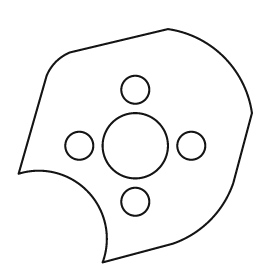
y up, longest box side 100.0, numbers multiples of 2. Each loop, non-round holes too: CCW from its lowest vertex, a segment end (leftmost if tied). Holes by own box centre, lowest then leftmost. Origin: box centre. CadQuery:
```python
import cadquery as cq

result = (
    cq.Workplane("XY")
    .moveTo(-14.0, -50.0)
    .lineTo(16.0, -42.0)
    .threePointArc((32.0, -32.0), (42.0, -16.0))
    .lineTo(50.0, 14.0)
    .threePointArc((38.0, 38.0), (14.0, 50.0))
    .lineTo(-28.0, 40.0)
    .threePointArc((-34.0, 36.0), (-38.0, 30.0))
    .lineTo(-50.0, -12.0)
    .threePointArc((-20.0, -20.0), (-14.0, -50.0))
    .close()
    .moveTo(0.0, -24.0)
    .circle(6.0)
    .moveTo(-24.0, 0.0)
    .circle(6.0)
    .moveTo(0.0, 0.0)
    .circle(14.0)
    .moveTo(24.0, 0.0)
    .circle(6.0)
    .moveTo(0.0, 24.0)
    .circle(6.0)
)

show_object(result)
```